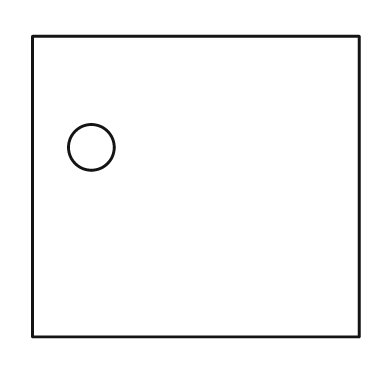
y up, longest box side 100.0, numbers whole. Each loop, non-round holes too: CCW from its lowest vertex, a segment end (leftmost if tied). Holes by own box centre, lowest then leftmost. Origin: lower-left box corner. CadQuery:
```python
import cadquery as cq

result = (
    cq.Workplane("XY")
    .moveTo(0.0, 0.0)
    .lineTo(100.0, 0.0)
    .lineTo(100.0, 92.0)
    .lineTo(0.0, 92.0)
    .close()
    .moveTo(18.0, 58.0)
    .circle(7.0)
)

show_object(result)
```